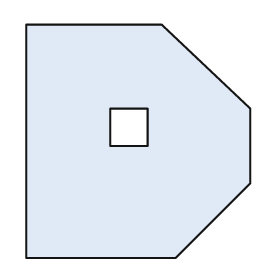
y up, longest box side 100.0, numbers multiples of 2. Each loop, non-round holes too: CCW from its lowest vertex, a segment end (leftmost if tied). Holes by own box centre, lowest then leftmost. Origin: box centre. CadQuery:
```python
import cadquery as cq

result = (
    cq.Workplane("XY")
    .moveTo(-48.0, -50.0)
    .lineTo(16.0, -50.0)
    .lineTo(48.0, -18.0)
    .lineTo(48.0, 14.0)
    .lineTo(10.0, 50.0)
    .lineTo(-48.0, 50.0)
    .close()
    .moveTo(-12.0, -2.0)
    .lineTo(4.0, -2.0)
    .lineTo(4.0, 14.0)
    .lineTo(-12.0, 14.0)
    .close()
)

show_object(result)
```